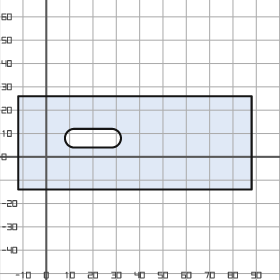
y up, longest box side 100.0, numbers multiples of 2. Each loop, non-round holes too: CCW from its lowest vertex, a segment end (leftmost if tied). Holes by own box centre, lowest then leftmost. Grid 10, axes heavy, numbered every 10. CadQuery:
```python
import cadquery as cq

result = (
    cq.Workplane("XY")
    .moveTo(-12.0, -14.0)
    .lineTo(88.0, -14.0)
    .lineTo(88.0, 26.0)
    .lineTo(-12.0, 26.0)
    .close()
    .moveTo(12.0, 4.0)
    .lineTo(28.0, 4.0)
    .threePointArc((32.0, 8.0), (28.0, 12.0))
    .lineTo(12.0, 12.0)
    .threePointArc((8.0, 8.0), (12.0, 4.0))
    .close()
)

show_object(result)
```